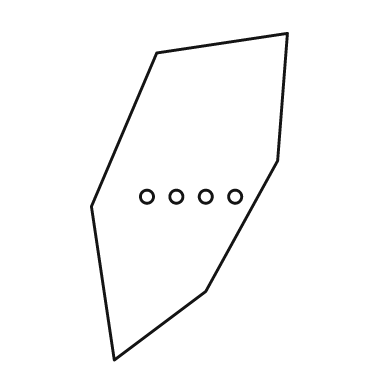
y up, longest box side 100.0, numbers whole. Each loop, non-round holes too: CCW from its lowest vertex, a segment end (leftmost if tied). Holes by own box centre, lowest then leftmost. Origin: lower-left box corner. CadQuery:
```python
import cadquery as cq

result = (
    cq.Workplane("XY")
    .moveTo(7.0, 0.0)
    .lineTo(35.0, 21.0)
    .lineTo(57.0, 61.0)
    .lineTo(60.0, 100.0)
    .lineTo(20.0, 94.0)
    .lineTo(0.0, 47.0)
    .close()
    .moveTo(17.0, 50.0)
    .circle(2.0)
    .moveTo(26.0, 50.0)
    .circle(2.0)
    .moveTo(35.0, 50.0)
    .circle(2.0)
    .moveTo(44.0, 50.0)
    .circle(2.0)
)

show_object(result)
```